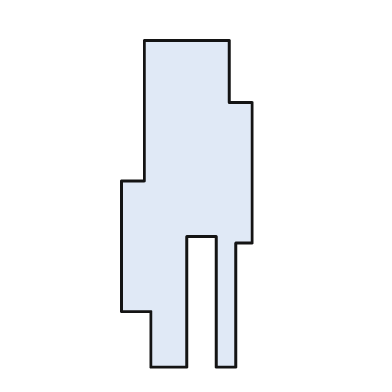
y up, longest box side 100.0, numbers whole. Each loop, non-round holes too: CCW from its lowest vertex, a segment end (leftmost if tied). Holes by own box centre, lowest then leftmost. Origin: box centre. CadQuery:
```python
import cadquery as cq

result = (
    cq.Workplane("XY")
    .moveTo(-11.0, -50.0)
    .lineTo(0.0, -50.0)
    .lineTo(0.0, -10.0)
    .lineTo(9.0, -10.0)
    .lineTo(9.0, -50.0)
    .lineTo(15.0, -50.0)
    .lineTo(15.0, -12.0)
    .lineTo(20.0, -12.0)
    .lineTo(20.0, 31.0)
    .lineTo(13.0, 31.0)
    .lineTo(13.0, 50.0)
    .lineTo(-13.0, 50.0)
    .lineTo(-13.0, 7.0)
    .lineTo(-20.0, 7.0)
    .lineTo(-20.0, -33.0)
    .lineTo(-11.0, -33.0)
    .close()
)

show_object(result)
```